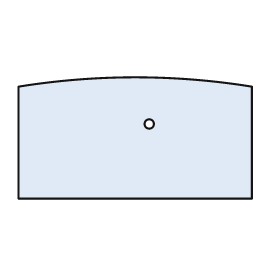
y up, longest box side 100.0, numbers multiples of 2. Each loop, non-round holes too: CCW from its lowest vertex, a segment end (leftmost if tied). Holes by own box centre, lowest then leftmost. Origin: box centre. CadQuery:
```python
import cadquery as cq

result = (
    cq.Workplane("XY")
    .moveTo(-50.0, -26.0)
    .lineTo(50.0, -26.0)
    .lineTo(50.0, 22.0)
    .threePointArc((0.0, 26.0), (-50.0, 22.0))
    .close()
    .moveTo(6.0, 6.0)
    .circle(2.0)
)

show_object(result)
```